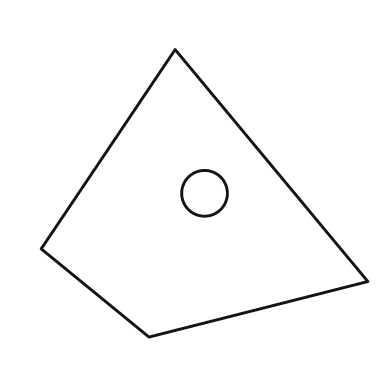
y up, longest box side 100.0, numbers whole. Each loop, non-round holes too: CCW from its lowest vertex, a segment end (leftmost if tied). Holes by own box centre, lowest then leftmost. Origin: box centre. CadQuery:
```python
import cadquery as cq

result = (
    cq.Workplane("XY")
    .moveTo(-17.0, -44.0)
    .lineTo(50.0, -27.0)
    .lineTo(-9.0, 44.0)
    .lineTo(-50.0, -17.0)
    .close()
    .moveTo(0.0, 0.0)
    .circle(7.0)
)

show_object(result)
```